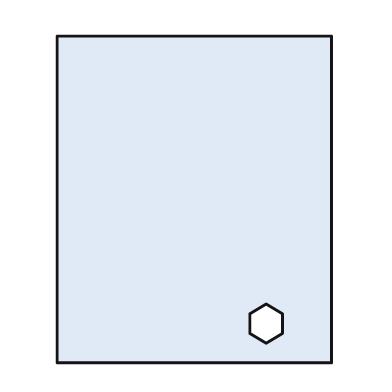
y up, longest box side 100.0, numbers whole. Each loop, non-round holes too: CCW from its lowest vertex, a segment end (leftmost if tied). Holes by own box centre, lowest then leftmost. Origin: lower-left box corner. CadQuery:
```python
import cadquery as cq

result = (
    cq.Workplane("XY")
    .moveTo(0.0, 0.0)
    .lineTo(84.0, 0.0)
    .lineTo(84.0, 100.0)
    .lineTo(0.0, 100.0)
    .close()
    .moveTo(64.0, 6.0)
    .lineTo(69.0, 9.0)
    .lineTo(69.0, 15.0)
    .lineTo(64.0, 18.0)
    .lineTo(59.0, 15.0)
    .lineTo(59.0, 9.0)
    .close()
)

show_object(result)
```